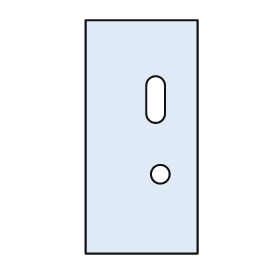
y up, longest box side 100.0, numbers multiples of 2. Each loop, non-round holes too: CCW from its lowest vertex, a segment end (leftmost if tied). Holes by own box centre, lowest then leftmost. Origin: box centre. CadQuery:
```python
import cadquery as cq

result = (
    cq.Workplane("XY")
    .moveTo(-24.0, -50.0)
    .lineTo(24.0, -50.0)
    .lineTo(24.0, 50.0)
    .lineTo(-24.0, 50.0)
    .close()
    .moveTo(8.0, -16.0)
    .circle(4.0)
    .moveTo(2.0, 10.0)
    .threePointArc((6.0, 6.0), (10.0, 10.0))
    .lineTo(10.0, 22.0)
    .threePointArc((6.0, 26.0), (2.0, 22.0))
    .close()
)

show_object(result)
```